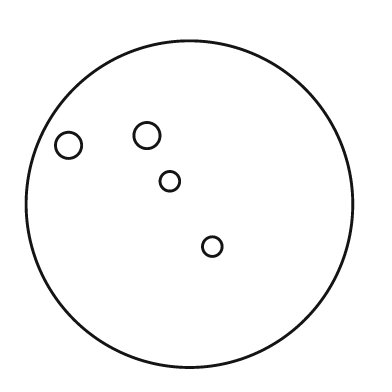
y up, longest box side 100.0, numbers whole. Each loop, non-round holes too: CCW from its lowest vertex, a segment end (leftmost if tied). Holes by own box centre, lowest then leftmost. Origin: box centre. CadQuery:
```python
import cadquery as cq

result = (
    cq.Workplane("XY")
    .moveTo(0.0, 0.0)
    .circle(50.0)
    .moveTo(7.0, -13.0)
    .circle(3.0)
    .moveTo(-6.0, 7.0)
    .circle(3.0)
    .moveTo(-37.0, 18.0)
    .circle(4.0)
    .moveTo(-13.0, 21.0)
    .circle(4.0)
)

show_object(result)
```